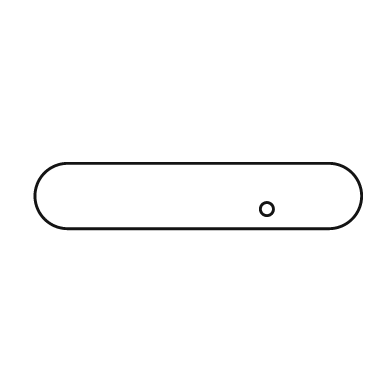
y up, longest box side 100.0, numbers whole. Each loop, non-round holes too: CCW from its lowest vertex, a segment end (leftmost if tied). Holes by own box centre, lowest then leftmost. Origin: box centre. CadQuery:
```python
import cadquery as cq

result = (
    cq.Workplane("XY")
    .moveTo(-40.0, -10.0)
    .lineTo(40.0, -10.0)
    .threePointArc((50.0, 0.0), (40.0, 10.0))
    .lineTo(-40.0, 10.0)
    .threePointArc((-50.0, 0.0), (-40.0, -10.0))
    .close()
    .moveTo(21.0, -4.0)
    .circle(2.0)
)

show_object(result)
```